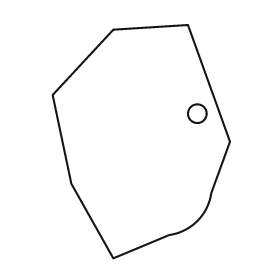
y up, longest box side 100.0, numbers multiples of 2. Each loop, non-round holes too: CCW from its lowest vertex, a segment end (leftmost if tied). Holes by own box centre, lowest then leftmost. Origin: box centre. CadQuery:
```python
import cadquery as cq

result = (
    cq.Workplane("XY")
    .moveTo(-12.0, -50.0)
    .lineTo(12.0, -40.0)
    .threePointArc((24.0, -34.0), (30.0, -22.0))
    .lineTo(38.0, 0.0)
    .lineTo(20.0, 50.0)
    .lineTo(-12.0, 48.0)
    .lineTo(-38.0, 20.0)
    .lineTo(-30.0, -18.0)
    .close()
    .moveTo(24.0, 12.0)
    .circle(4.0)
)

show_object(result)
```